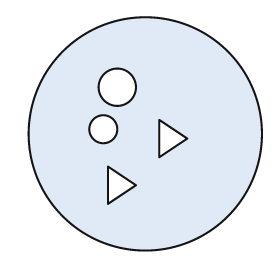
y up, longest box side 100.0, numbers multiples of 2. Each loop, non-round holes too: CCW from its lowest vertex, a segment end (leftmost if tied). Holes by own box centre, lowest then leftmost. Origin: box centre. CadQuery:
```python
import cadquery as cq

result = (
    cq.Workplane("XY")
    .moveTo(0.0, 0.0)
    .circle(50.0)
    .moveTo(-16.0, -30.0)
    .lineTo(-4.0, -22.0)
    .lineTo(-16.0, -14.0)
    .close()
    .moveTo(6.0, -10.0)
    .lineTo(18.0, -2.0)
    .lineTo(6.0, 6.0)
    .close()
    .moveTo(-18.0, 2.0)
    .circle(6.0)
    .moveTo(-12.0, 20.0)
    .circle(8.0)
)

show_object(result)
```